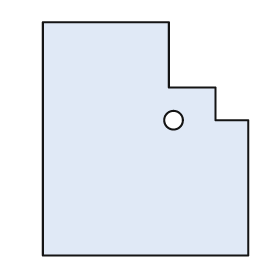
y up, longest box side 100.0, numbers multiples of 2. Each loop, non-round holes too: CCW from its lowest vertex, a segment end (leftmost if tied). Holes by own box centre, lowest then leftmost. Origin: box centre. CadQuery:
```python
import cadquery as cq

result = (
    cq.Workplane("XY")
    .moveTo(-44.0, -50.0)
    .lineTo(44.0, -50.0)
    .lineTo(44.0, 8.0)
    .lineTo(30.0, 8.0)
    .lineTo(30.0, 22.0)
    .lineTo(10.0, 22.0)
    .lineTo(10.0, 50.0)
    .lineTo(-44.0, 50.0)
    .close()
    .moveTo(12.0, 8.0)
    .circle(4.0)
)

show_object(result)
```